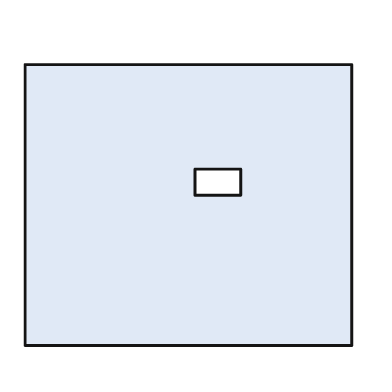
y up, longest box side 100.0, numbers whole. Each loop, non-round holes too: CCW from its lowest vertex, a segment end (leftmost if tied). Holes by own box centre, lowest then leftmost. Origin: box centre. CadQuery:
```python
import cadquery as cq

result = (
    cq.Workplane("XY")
    .moveTo(-50.0, -43.0)
    .lineTo(50.0, -43.0)
    .lineTo(50.0, 43.0)
    .lineTo(-50.0, 43.0)
    .close()
    .moveTo(2.0, 3.0)
    .lineTo(16.0, 3.0)
    .lineTo(16.0, 11.0)
    .lineTo(2.0, 11.0)
    .close()
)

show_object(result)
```